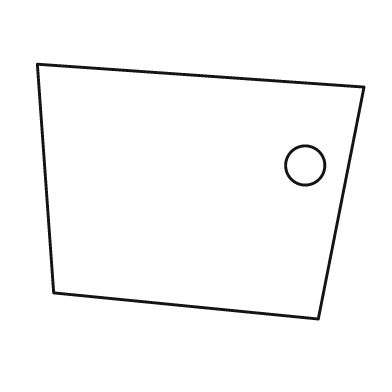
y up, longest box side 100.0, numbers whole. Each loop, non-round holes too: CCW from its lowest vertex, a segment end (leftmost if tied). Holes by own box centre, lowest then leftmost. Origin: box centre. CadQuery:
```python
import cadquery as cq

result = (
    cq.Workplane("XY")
    .moveTo(36.0, -39.0)
    .lineTo(50.0, 32.0)
    .lineTo(-50.0, 39.0)
    .lineTo(-45.0, -31.0)
    .close()
    .moveTo(32.0, 8.0)
    .circle(6.0)
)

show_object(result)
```